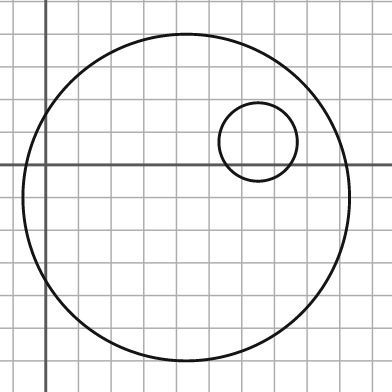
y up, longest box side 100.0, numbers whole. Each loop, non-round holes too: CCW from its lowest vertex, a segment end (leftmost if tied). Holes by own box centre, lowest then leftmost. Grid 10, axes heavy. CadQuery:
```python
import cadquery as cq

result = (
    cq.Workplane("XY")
    .moveTo(43.0, -10.0)
    .circle(50.0)
    .moveTo(65.0, 7.0)
    .circle(12.0)
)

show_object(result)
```